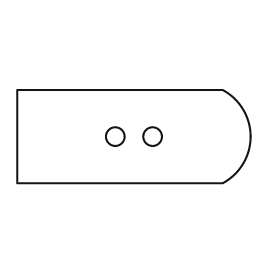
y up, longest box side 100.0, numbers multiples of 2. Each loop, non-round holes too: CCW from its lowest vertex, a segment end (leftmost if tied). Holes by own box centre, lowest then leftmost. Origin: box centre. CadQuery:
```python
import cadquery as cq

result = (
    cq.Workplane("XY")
    .moveTo(-50.0, -20.0)
    .lineTo(38.0, -20.0)
    .threePointArc((50.0, 0.0), (38.0, 20.0))
    .lineTo(-50.0, 20.0)
    .close()
    .moveTo(-8.0, 0.0)
    .circle(4.0)
    .moveTo(8.0, 0.0)
    .circle(4.0)
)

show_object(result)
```